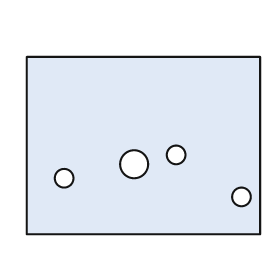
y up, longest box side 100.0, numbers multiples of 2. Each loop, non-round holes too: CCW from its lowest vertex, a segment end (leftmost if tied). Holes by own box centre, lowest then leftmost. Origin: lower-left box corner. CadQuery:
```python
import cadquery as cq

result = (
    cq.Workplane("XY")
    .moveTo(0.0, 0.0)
    .lineTo(100.0, 0.0)
    .lineTo(100.0, 76.0)
    .lineTo(0.0, 76.0)
    .close()
    .moveTo(92.0, 16.0)
    .circle(4.0)
    .moveTo(16.0, 24.0)
    .circle(4.0)
    .moveTo(46.0, 30.0)
    .circle(6.0)
    .moveTo(64.0, 34.0)
    .circle(4.0)
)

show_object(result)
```